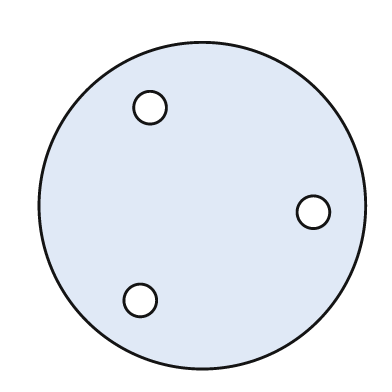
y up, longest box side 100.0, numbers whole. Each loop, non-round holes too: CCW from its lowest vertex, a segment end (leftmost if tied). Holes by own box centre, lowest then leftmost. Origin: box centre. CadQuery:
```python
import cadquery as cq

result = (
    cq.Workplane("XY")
    .moveTo(0.0, 0.0)
    .circle(50.0)
    .moveTo(-19.0, -29.0)
    .circle(5.0)
    .moveTo(34.0, -2.0)
    .circle(5.0)
    .moveTo(-16.0, 30.0)
    .circle(5.0)
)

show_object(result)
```